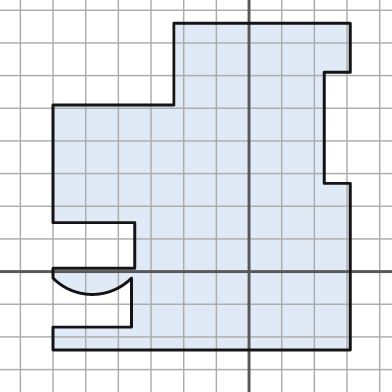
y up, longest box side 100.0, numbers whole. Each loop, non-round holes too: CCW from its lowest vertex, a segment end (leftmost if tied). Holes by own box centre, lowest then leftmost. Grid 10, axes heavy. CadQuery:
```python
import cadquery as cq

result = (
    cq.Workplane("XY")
    .moveTo(-60.0, -24.0)
    .lineTo(31.0, -24.0)
    .lineTo(31.0, 27.0)
    .lineTo(23.0, 27.0)
    .lineTo(23.0, 61.0)
    .lineTo(31.0, 61.0)
    .lineTo(31.0, 76.0)
    .lineTo(-23.0, 76.0)
    .lineTo(-23.0, 51.0)
    .lineTo(-60.0, 51.0)
    .lineTo(-60.0, 15.0)
    .lineTo(-35.0, 15.0)
    .lineTo(-35.0, 1.0)
    .lineTo(-60.0, 1.0)
    .lineTo(-60.0, -2.0)
    .threePointArc((-48.0, -7.0), (-36.0, -2.0))
    .lineTo(-36.0, -17.0)
    .lineTo(-60.0, -17.0)
    .close()
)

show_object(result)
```